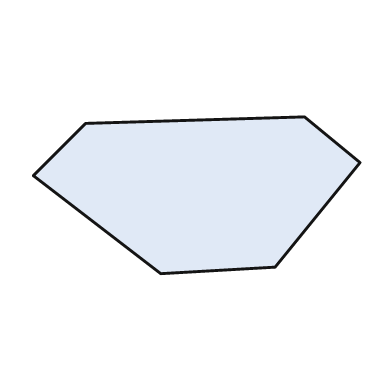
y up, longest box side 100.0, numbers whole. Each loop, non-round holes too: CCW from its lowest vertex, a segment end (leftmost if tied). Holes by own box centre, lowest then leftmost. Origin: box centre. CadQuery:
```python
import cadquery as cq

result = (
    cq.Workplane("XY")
    .moveTo(-11.0, -24.0)
    .lineTo(24.0, -22.0)
    .lineTo(50.0, 10.0)
    .lineTo(33.0, 24.0)
    .lineTo(-34.0, 22.0)
    .lineTo(-50.0, 6.0)
    .close()
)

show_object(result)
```